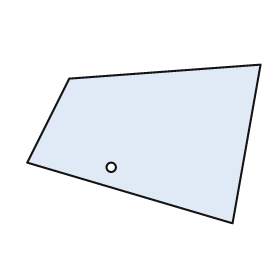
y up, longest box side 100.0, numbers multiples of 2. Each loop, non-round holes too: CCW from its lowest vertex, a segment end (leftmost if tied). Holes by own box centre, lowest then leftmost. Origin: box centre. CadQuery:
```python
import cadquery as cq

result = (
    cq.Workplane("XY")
    .moveTo(38.0, -34.0)
    .lineTo(50.0, 34.0)
    .lineTo(-32.0, 28.0)
    .lineTo(-50.0, -8.0)
    .close()
    .moveTo(-14.0, -10.0)
    .circle(2.0)
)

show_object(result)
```